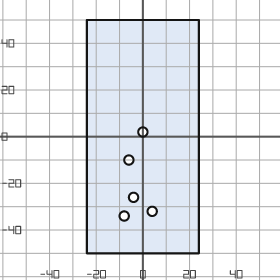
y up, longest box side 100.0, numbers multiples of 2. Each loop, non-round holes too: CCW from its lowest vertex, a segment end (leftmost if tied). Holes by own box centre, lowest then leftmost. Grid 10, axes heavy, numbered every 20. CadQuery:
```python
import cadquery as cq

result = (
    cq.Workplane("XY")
    .moveTo(-24.0, -50.0)
    .lineTo(24.0, -50.0)
    .lineTo(24.0, 50.0)
    .lineTo(-24.0, 50.0)
    .close()
    .moveTo(-8.0, -34.0)
    .circle(2.0)
    .moveTo(4.0, -32.0)
    .circle(2.0)
    .moveTo(-4.0, -26.0)
    .circle(2.0)
    .moveTo(-6.0, -10.0)
    .circle(2.0)
    .moveTo(0.0, 2.0)
    .circle(2.0)
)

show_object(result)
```